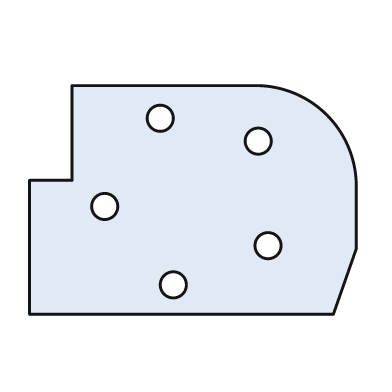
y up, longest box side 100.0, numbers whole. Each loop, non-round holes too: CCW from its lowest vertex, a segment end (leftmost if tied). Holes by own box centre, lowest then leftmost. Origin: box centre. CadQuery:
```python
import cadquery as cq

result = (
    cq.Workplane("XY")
    .moveTo(-50.0, -35.0)
    .lineTo(43.0, -35.0)
    .lineTo(50.0, -15.0)
    .lineTo(50.0, 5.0)
    .threePointArc((41.0, 26.0), (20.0, 35.0))
    .lineTo(-37.0, 35.0)
    .lineTo(-37.0, 6.0)
    .lineTo(-50.0, 6.0)
    .close()
    .moveTo(-6.0, -26.0)
    .circle(4.0)
    .moveTo(23.0, -14.0)
    .circle(4.0)
    .moveTo(-27.0, -2.0)
    .circle(4.0)
    .moveTo(20.0, 18.0)
    .circle(4.0)
    .moveTo(-10.0, 25.0)
    .circle(4.0)
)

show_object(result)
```